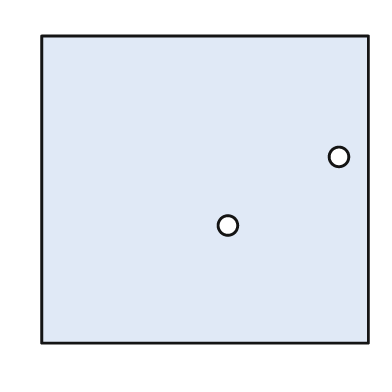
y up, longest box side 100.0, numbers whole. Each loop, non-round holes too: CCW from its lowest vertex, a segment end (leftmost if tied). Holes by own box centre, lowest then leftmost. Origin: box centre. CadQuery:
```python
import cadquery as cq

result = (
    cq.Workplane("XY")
    .moveTo(-50.0, -47.0)
    .lineTo(50.0, -47.0)
    .lineTo(50.0, 47.0)
    .lineTo(-50.0, 47.0)
    .close()
    .moveTo(7.0, -11.0)
    .circle(3.0)
    .moveTo(41.0, 10.0)
    .circle(3.0)
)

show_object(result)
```